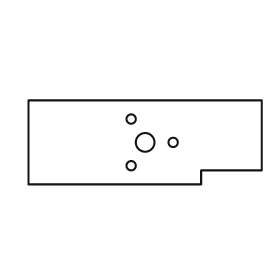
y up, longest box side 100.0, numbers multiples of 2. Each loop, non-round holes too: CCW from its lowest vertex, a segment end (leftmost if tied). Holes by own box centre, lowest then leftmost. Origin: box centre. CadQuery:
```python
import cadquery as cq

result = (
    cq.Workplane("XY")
    .moveTo(-50.0, -18.0)
    .lineTo(24.0, -18.0)
    .lineTo(24.0, -12.0)
    .lineTo(50.0, -12.0)
    .lineTo(50.0, 18.0)
    .lineTo(-50.0, 18.0)
    .close()
    .moveTo(-6.0, -10.0)
    .circle(2.0)
    .moveTo(0.0, 0.0)
    .circle(4.0)
    .moveTo(12.0, 0.0)
    .circle(2.0)
    .moveTo(-6.0, 10.0)
    .circle(2.0)
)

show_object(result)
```